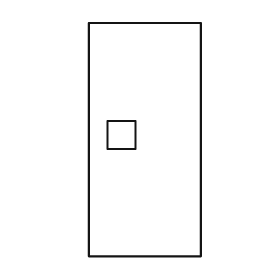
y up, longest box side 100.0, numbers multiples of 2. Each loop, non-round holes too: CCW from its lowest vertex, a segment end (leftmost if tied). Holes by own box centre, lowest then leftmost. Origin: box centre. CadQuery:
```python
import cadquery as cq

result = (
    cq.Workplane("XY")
    .moveTo(-24.0, -50.0)
    .lineTo(24.0, -50.0)
    .lineTo(24.0, 50.0)
    .lineTo(-24.0, 50.0)
    .close()
    .moveTo(-16.0, -4.0)
    .lineTo(-4.0, -4.0)
    .lineTo(-4.0, 8.0)
    .lineTo(-16.0, 8.0)
    .close()
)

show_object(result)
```